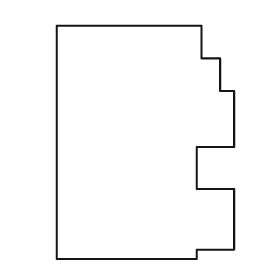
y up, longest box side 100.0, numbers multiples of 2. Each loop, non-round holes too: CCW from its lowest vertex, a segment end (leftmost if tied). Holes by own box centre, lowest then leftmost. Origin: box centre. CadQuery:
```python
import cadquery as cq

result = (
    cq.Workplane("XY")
    .moveTo(-38.0, -50.0)
    .lineTo(22.0, -50.0)
    .lineTo(22.0, -46.0)
    .lineTo(38.0, -46.0)
    .lineTo(38.0, -20.0)
    .lineTo(22.0, -20.0)
    .lineTo(22.0, -2.0)
    .lineTo(38.0, -2.0)
    .lineTo(38.0, 22.0)
    .lineTo(32.0, 22.0)
    .lineTo(32.0, 36.0)
    .lineTo(24.0, 36.0)
    .lineTo(24.0, 50.0)
    .lineTo(-38.0, 50.0)
    .close()
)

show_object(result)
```